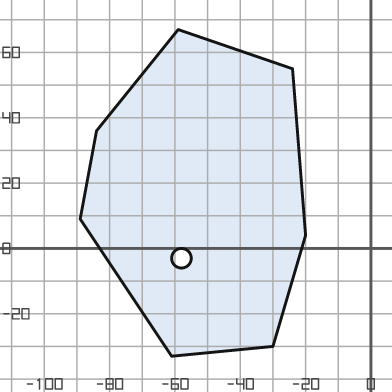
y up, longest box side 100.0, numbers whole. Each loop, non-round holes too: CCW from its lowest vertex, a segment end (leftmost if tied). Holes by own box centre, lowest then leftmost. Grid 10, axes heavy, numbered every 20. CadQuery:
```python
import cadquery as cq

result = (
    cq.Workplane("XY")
    .moveTo(-61.0, -33.0)
    .lineTo(-30.0, -30.0)
    .lineTo(-20.0, 4.0)
    .lineTo(-24.0, 55.0)
    .lineTo(-59.0, 67.0)
    .lineTo(-84.0, 36.0)
    .lineTo(-89.0, 9.0)
    .close()
    .moveTo(-58.0, -3.0)
    .circle(3.0)
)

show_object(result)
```